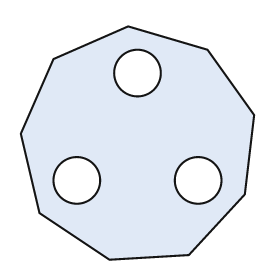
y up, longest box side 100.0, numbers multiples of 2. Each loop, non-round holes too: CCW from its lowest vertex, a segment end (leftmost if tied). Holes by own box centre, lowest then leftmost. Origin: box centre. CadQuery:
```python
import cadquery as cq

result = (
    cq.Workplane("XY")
    .moveTo(-12.0, -50.0)
    .lineTo(22.0, -48.0)
    .lineTo(46.0, -22.0)
    .lineTo(50.0, 12.0)
    .lineTo(30.0, 40.0)
    .lineTo(-4.0, 50.0)
    .lineTo(-36.0, 36.0)
    .lineTo(-50.0, 4.0)
    .lineTo(-42.0, -30.0)
    .close()
    .moveTo(-26.0, -16.0)
    .circle(10.0)
    .moveTo(26.0, -16.0)
    .circle(10.0)
    .moveTo(0.0, 30.0)
    .circle(10.0)
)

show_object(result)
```